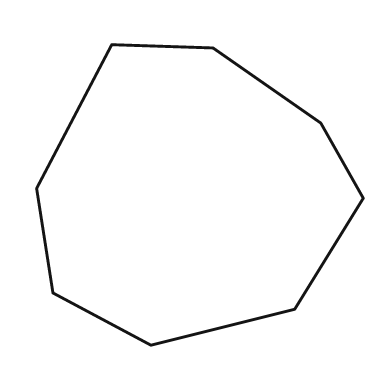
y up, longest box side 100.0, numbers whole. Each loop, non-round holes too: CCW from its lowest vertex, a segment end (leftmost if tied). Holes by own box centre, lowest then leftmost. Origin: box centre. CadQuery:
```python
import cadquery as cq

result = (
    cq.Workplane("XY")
    .moveTo(-15.0, -46.0)
    .lineTo(29.0, -35.0)
    .lineTo(50.0, -1.0)
    .lineTo(37.0, 22.0)
    .lineTo(4.0, 45.0)
    .lineTo(-27.0, 46.0)
    .lineTo(-50.0, 2.0)
    .lineTo(-45.0, -30.0)
    .close()
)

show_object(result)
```